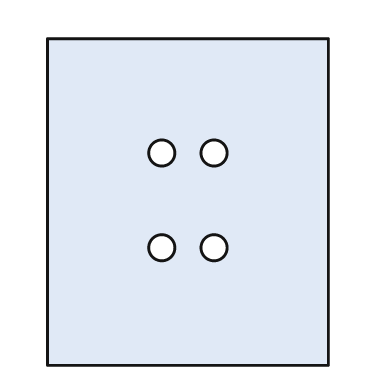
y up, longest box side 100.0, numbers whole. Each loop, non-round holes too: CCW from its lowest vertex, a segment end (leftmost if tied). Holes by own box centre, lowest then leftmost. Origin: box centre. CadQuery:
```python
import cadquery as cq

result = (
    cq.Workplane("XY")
    .moveTo(-43.0, -50.0)
    .lineTo(43.0, -50.0)
    .lineTo(43.0, 50.0)
    .lineTo(-43.0, 50.0)
    .close()
    .moveTo(-8.0, -14.0)
    .circle(4.0)
    .moveTo(8.0, -14.0)
    .circle(4.0)
    .moveTo(-8.0, 15.0)
    .circle(4.0)
    .moveTo(8.0, 15.0)
    .circle(4.0)
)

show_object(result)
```